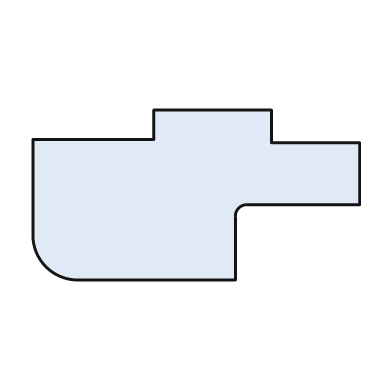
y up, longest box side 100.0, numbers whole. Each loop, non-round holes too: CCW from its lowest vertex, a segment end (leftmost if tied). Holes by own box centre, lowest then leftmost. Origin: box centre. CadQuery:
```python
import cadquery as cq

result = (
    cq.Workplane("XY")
    .moveTo(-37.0, -26.0)
    .lineTo(12.0, -26.0)
    .lineTo(12.0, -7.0)
    .threePointArc((13.0, -4.0), (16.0, -3.0))
    .lineTo(50.0, -3.0)
    .lineTo(50.0, 16.0)
    .lineTo(23.0, 16.0)
    .lineTo(23.0, 26.0)
    .lineTo(-13.0, 26.0)
    .lineTo(-13.0, 17.0)
    .lineTo(-50.0, 17.0)
    .lineTo(-50.0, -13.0)
    .threePointArc((-46.0, -22.0), (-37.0, -26.0))
    .close()
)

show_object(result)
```